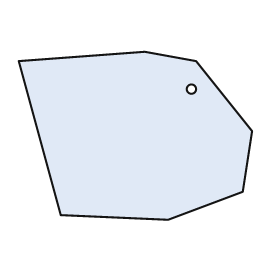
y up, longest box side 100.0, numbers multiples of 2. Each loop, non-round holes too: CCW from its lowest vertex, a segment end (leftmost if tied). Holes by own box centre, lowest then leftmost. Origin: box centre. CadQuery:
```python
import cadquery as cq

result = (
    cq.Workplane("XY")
    .moveTo(14.0, -36.0)
    .lineTo(46.0, -24.0)
    .lineTo(50.0, 2.0)
    .lineTo(26.0, 32.0)
    .lineTo(4.0, 36.0)
    .lineTo(-50.0, 32.0)
    .lineTo(-32.0, -34.0)
    .close()
    .moveTo(24.0, 20.0)
    .circle(2.0)
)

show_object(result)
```